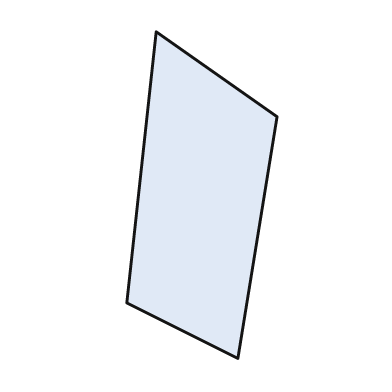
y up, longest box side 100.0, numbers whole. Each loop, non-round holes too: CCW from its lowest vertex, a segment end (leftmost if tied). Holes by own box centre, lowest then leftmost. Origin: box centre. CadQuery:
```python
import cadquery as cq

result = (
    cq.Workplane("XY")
    .moveTo(11.0, -50.0)
    .lineTo(23.0, 24.0)
    .lineTo(-14.0, 50.0)
    .lineTo(-23.0, -33.0)
    .close()
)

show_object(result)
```